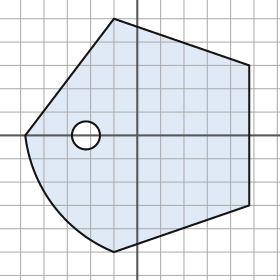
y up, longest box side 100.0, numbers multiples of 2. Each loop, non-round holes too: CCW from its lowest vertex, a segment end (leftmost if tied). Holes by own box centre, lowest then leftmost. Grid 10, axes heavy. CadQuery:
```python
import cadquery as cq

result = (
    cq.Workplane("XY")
    .moveTo(-10.0, -50.0)
    .lineTo(48.0, -30.0)
    .lineTo(48.0, 30.0)
    .lineTo(-10.0, 50.0)
    .lineTo(-48.0, 0.0)
    .threePointArc((-36.0, -30.0), (-10.0, -50.0))
    .close()
    .moveTo(-22.0, 0.0)
    .circle(6.0)
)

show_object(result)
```